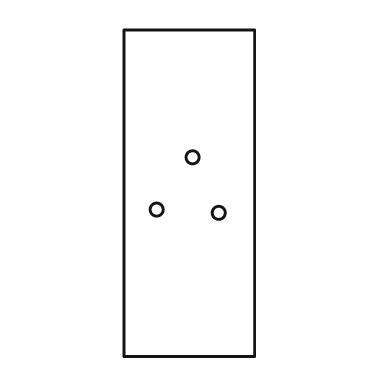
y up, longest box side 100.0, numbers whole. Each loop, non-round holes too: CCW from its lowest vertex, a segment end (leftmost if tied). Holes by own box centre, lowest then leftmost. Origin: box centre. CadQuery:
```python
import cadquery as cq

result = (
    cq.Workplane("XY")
    .moveTo(-20.0, -50.0)
    .lineTo(20.0, -50.0)
    .lineTo(20.0, 50.0)
    .lineTo(-20.0, 50.0)
    .close()
    .moveTo(9.0, -6.0)
    .circle(2.0)
    .moveTo(-10.0, -5.0)
    .circle(2.0)
    .moveTo(1.0, 11.0)
    .circle(2.0)
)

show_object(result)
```